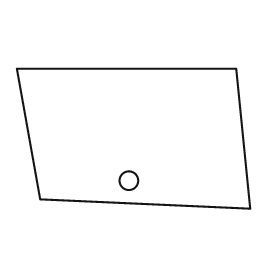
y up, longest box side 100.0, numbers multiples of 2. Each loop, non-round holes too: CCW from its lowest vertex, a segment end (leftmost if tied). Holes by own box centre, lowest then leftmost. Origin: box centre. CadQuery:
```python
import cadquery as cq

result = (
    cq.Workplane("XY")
    .moveTo(50.0, -30.0)
    .lineTo(44.0, 30.0)
    .lineTo(-50.0, 30.0)
    .lineTo(-40.0, -26.0)
    .close()
    .moveTo(-2.0, -18.0)
    .circle(4.0)
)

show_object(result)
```